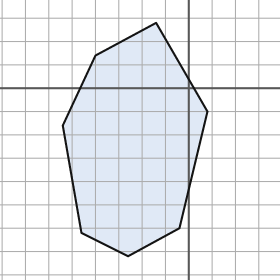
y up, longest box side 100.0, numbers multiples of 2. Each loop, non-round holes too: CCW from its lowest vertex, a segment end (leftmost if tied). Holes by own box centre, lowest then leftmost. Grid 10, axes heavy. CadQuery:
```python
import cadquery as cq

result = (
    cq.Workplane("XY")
    .moveTo(-26.0, -72.0)
    .lineTo(-4.0, -60.0)
    .lineTo(8.0, -10.0)
    .lineTo(-14.0, 28.0)
    .lineTo(-40.0, 14.0)
    .lineTo(-54.0, -16.0)
    .lineTo(-46.0, -62.0)
    .close()
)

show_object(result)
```